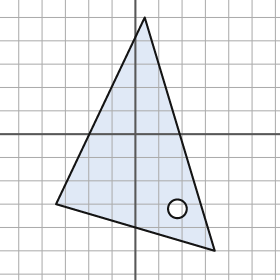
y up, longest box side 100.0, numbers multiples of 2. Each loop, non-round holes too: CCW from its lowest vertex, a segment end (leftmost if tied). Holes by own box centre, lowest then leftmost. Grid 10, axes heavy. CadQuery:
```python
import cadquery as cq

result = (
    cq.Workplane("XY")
    .moveTo(34.0, -50.0)
    .lineTo(4.0, 50.0)
    .lineTo(-34.0, -30.0)
    .close()
    .moveTo(18.0, -32.0)
    .circle(4.0)
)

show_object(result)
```